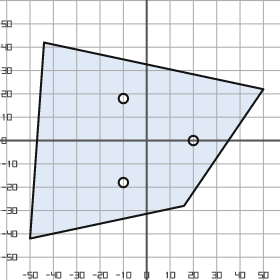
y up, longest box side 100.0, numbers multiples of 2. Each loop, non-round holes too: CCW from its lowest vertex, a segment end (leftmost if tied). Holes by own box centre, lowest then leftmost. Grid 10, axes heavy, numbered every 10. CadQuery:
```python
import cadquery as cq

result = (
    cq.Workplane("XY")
    .moveTo(-50.0, -42.0)
    .lineTo(16.0, -28.0)
    .lineTo(50.0, 22.0)
    .lineTo(-44.0, 42.0)
    .close()
    .moveTo(-10.0, -18.0)
    .circle(2.0)
    .moveTo(20.0, 0.0)
    .circle(2.0)
    .moveTo(-10.0, 18.0)
    .circle(2.0)
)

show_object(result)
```